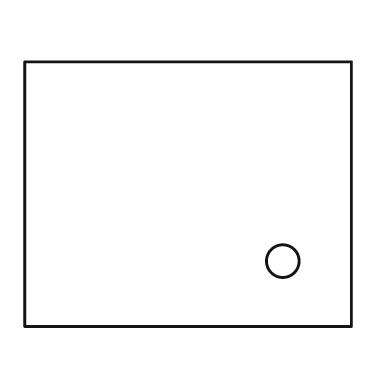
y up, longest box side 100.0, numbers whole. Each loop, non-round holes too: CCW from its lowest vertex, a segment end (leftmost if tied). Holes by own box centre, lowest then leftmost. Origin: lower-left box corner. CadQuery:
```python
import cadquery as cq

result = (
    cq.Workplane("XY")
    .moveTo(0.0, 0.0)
    .lineTo(100.0, 0.0)
    .lineTo(100.0, 81.0)
    .lineTo(0.0, 81.0)
    .close()
    .moveTo(79.0, 20.0)
    .circle(5.0)
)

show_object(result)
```